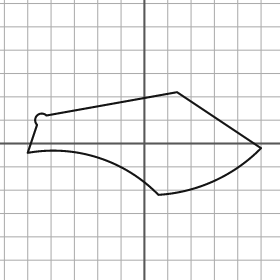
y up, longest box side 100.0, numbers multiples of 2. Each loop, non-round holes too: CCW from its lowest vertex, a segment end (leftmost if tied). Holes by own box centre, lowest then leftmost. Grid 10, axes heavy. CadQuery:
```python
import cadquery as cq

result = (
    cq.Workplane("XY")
    .moveTo(6.0, -22.0)
    .threePointArc((30.0, -16.0), (50.0, -2.0))
    .lineTo(14.0, 22.0)
    .lineTo(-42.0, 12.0)
    .threePointArc((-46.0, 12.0), (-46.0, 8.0))
    .lineTo(-50.0, -4.0)
    .threePointArc((-20.0, -6.0), (6.0, -22.0))
    .close()
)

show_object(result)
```